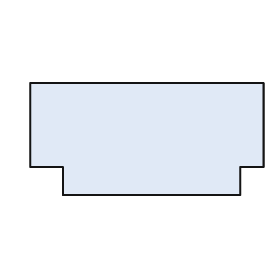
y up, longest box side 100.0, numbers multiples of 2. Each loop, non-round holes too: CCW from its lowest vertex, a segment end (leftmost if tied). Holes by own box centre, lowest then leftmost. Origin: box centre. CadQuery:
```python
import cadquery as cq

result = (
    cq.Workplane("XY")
    .moveTo(-36.0, -24.0)
    .lineTo(40.0, -24.0)
    .lineTo(40.0, -12.0)
    .lineTo(50.0, -12.0)
    .lineTo(50.0, 24.0)
    .lineTo(-50.0, 24.0)
    .lineTo(-50.0, -12.0)
    .lineTo(-36.0, -12.0)
    .close()
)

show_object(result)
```